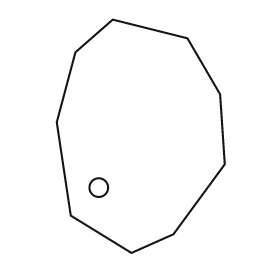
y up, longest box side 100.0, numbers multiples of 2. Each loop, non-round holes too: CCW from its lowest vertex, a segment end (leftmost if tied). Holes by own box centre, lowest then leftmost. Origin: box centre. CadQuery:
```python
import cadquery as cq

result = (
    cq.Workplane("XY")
    .moveTo(-4.0, -50.0)
    .lineTo(14.0, -42.0)
    .lineTo(36.0, -12.0)
    .lineTo(34.0, 18.0)
    .lineTo(20.0, 42.0)
    .lineTo(-12.0, 50.0)
    .lineTo(-28.0, 36.0)
    .lineTo(-36.0, 6.0)
    .lineTo(-30.0, -34.0)
    .close()
    .moveTo(-18.0, -22.0)
    .circle(4.0)
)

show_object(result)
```